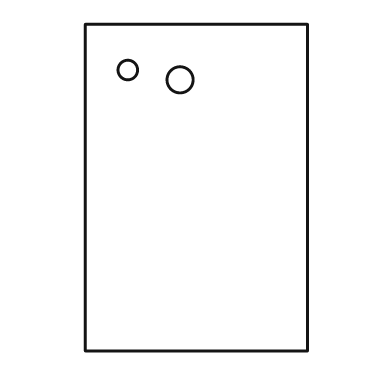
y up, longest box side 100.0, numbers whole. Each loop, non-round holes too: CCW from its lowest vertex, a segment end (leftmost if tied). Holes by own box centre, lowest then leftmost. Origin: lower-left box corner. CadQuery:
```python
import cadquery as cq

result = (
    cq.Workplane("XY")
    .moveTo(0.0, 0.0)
    .lineTo(68.0, 0.0)
    .lineTo(68.0, 100.0)
    .lineTo(0.0, 100.0)
    .close()
    .moveTo(29.0, 83.0)
    .circle(4.0)
    .moveTo(13.0, 86.0)
    .circle(3.0)
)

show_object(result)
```